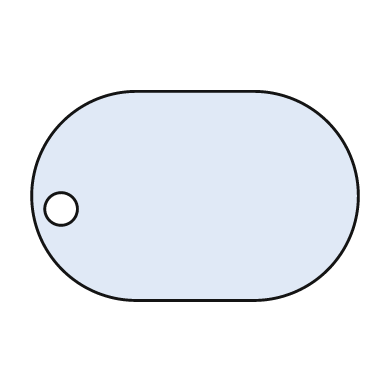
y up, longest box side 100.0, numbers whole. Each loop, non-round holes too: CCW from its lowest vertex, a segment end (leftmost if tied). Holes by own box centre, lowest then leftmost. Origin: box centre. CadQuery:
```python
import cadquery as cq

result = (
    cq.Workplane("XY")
    .moveTo(-18.0, -32.0)
    .lineTo(18.0, -32.0)
    .threePointArc((50.0, 0.0), (18.0, 32.0))
    .lineTo(-18.0, 32.0)
    .threePointArc((-50.0, 0.0), (-18.0, -32.0))
    .close()
    .moveTo(-41.0, -4.0)
    .circle(5.0)
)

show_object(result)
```